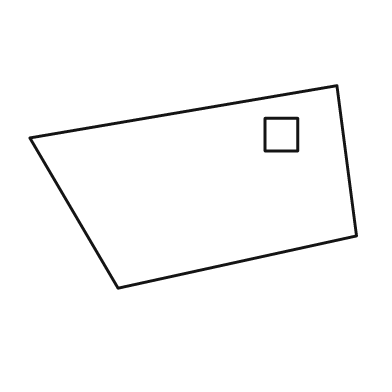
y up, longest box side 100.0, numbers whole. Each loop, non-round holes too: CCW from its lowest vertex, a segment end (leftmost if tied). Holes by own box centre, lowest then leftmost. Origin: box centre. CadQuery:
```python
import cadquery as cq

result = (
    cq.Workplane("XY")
    .moveTo(-23.0, -31.0)
    .lineTo(50.0, -15.0)
    .lineTo(44.0, 31.0)
    .lineTo(-50.0, 15.0)
    .close()
    .moveTo(22.0, 11.0)
    .lineTo(32.0, 11.0)
    .lineTo(32.0, 21.0)
    .lineTo(22.0, 21.0)
    .close()
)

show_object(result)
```